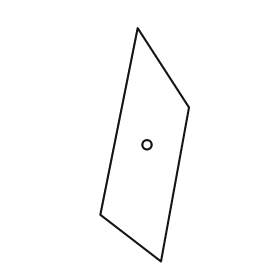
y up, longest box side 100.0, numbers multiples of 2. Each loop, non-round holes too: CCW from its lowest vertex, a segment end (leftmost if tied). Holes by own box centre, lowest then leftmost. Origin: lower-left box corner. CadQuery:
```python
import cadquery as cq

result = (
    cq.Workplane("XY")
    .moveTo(26.0, 0.0)
    .lineTo(38.0, 66.0)
    .lineTo(16.0, 100.0)
    .lineTo(0.0, 20.0)
    .close()
    .moveTo(20.0, 50.0)
    .circle(2.0)
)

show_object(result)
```